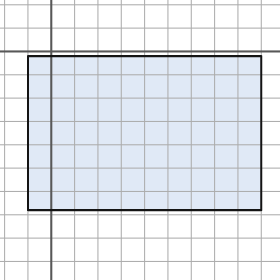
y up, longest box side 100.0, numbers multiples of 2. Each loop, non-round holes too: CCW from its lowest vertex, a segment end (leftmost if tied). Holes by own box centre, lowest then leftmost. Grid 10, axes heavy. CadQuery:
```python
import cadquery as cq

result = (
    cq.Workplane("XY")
    .moveTo(-10.0, -68.0)
    .lineTo(90.0, -68.0)
    .lineTo(90.0, -2.0)
    .lineTo(-10.0, -2.0)
    .close()
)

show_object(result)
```